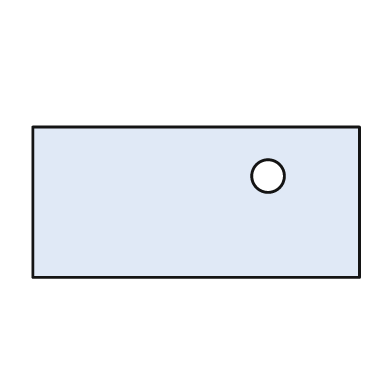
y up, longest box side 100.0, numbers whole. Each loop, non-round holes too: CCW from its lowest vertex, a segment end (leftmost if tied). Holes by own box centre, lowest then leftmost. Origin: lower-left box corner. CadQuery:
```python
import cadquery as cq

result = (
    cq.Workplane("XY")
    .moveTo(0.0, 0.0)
    .lineTo(100.0, 0.0)
    .lineTo(100.0, 46.0)
    .lineTo(0.0, 46.0)
    .close()
    .moveTo(72.0, 31.0)
    .circle(5.0)
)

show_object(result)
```